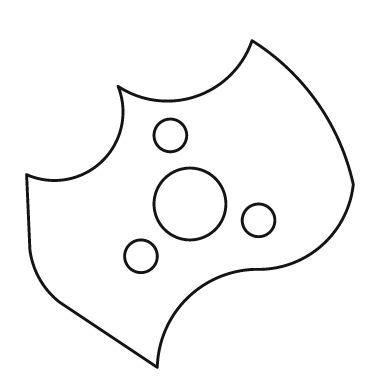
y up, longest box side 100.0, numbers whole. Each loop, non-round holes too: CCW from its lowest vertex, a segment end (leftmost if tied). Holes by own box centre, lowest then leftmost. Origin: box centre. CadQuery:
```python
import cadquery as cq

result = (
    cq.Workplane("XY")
    .moveTo(-10.0, -50.0)
    .threePointArc((-1.0, -29.0), (20.0, -20.0))
    .threePointArc((40.0, -13.0), (50.0, 6.0))
    .threePointArc((39.0, 31.0), (19.0, 50.0))
    .threePointArc((2.0, 33.0), (-22.0, 36.0))
    .threePointArc((-27.0, 13.0), (-50.0, 9.0))
    .lineTo(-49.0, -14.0)
    .threePointArc((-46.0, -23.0), (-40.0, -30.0))
    .close()
    .moveTo(-15.0, -16.0)
    .circle(5.0)
    .moveTo(21.0, -5.0)
    .circle(5.0)
    .moveTo(0.0, 0.0)
    .circle(11.0)
    .moveTo(-6.0, 21.0)
    .circle(5.0)
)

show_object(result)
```